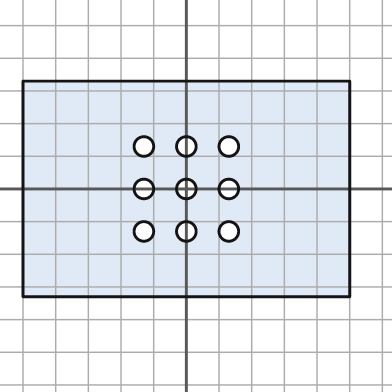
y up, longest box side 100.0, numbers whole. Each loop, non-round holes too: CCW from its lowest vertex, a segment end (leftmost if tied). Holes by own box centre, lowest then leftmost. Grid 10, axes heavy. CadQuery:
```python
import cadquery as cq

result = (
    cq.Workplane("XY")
    .moveTo(-50.0, -33.0)
    .lineTo(50.0, -33.0)
    .lineTo(50.0, 33.0)
    .lineTo(-50.0, 33.0)
    .close()
    .moveTo(-13.0, -13.0)
    .circle(3.0)
    .moveTo(0.0, -13.0)
    .circle(3.0)
    .moveTo(13.0, -13.0)
    .circle(3.0)
    .moveTo(-13.0, 0.0)
    .circle(3.0)
    .moveTo(0.0, 0.0)
    .circle(3.0)
    .moveTo(13.0, 0.0)
    .circle(3.0)
    .moveTo(-13.0, 13.0)
    .circle(3.0)
    .moveTo(0.0, 13.0)
    .circle(3.0)
    .moveTo(13.0, 13.0)
    .circle(3.0)
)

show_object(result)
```